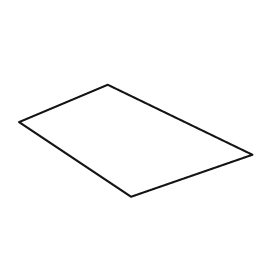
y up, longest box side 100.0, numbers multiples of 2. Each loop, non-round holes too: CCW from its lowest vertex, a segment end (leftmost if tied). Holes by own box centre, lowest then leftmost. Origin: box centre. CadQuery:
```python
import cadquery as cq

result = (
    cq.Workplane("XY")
    .moveTo(-2.0, -24.0)
    .lineTo(50.0, -6.0)
    .lineTo(-12.0, 24.0)
    .lineTo(-50.0, 8.0)
    .close()
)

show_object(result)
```